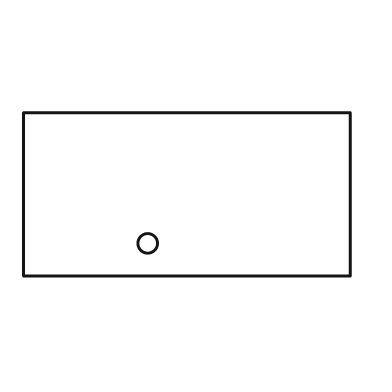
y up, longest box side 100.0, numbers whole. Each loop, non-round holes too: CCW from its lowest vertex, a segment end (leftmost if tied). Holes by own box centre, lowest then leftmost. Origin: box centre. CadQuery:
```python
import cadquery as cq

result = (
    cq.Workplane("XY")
    .moveTo(-50.0, -25.0)
    .lineTo(50.0, -25.0)
    .lineTo(50.0, 25.0)
    .lineTo(-50.0, 25.0)
    .close()
    .moveTo(-12.0, -15.0)
    .circle(3.0)
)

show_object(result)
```